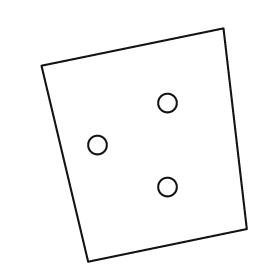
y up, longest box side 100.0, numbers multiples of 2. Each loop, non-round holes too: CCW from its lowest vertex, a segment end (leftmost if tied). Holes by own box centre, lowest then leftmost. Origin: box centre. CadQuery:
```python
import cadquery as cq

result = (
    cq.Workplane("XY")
    .moveTo(-24.0, -50.0)
    .lineTo(44.0, -36.0)
    .lineTo(34.0, 50.0)
    .lineTo(-44.0, 34.0)
    .close()
    .moveTo(10.0, -18.0)
    .circle(4.0)
    .moveTo(-20.0, 0.0)
    .circle(4.0)
    .moveTo(10.0, 18.0)
    .circle(4.0)
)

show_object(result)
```